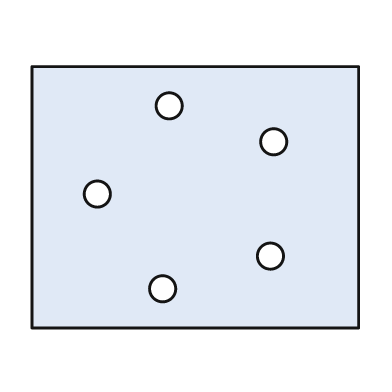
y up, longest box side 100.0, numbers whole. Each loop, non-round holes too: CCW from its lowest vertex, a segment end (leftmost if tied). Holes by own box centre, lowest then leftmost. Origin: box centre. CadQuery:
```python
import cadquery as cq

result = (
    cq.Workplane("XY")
    .moveTo(-50.0, -40.0)
    .lineTo(50.0, -40.0)
    .lineTo(50.0, 40.0)
    .lineTo(-50.0, 40.0)
    .close()
    .moveTo(-10.0, -28.0)
    .circle(4.0)
    .moveTo(23.0, -18.0)
    .circle(4.0)
    .moveTo(-30.0, 1.0)
    .circle(4.0)
    .moveTo(24.0, 17.0)
    .circle(4.0)
    .moveTo(-8.0, 28.0)
    .circle(4.0)
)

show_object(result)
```